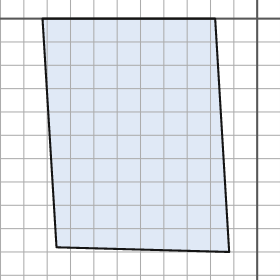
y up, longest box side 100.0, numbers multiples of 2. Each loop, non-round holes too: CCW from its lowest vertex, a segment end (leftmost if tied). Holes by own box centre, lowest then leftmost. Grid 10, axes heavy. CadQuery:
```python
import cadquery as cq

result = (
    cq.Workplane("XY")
    .moveTo(-12.0, -100.0)
    .lineTo(-18.0, 0.0)
    .lineTo(-92.0, 0.0)
    .lineTo(-86.0, -98.0)
    .close()
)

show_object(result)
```